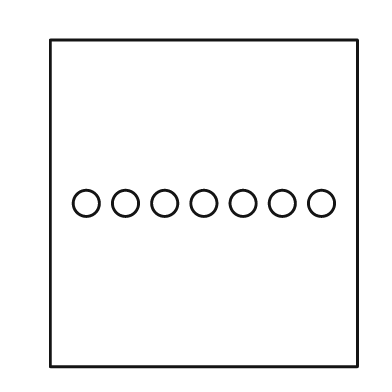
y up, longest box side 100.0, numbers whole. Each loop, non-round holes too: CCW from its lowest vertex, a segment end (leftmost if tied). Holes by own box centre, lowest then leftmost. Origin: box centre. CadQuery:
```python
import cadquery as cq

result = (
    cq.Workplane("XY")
    .moveTo(-47.0, -50.0)
    .lineTo(47.0, -50.0)
    .lineTo(47.0, 50.0)
    .lineTo(-47.0, 50.0)
    .close()
    .moveTo(-36.0, 0.0)
    .circle(4.0)
    .moveTo(-24.0, 0.0)
    .circle(4.0)
    .moveTo(-12.0, 0.0)
    .circle(4.0)
    .moveTo(0.0, 0.0)
    .circle(4.0)
    .moveTo(12.0, 0.0)
    .circle(4.0)
    .moveTo(24.0, 0.0)
    .circle(4.0)
    .moveTo(36.0, 0.0)
    .circle(4.0)
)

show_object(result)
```